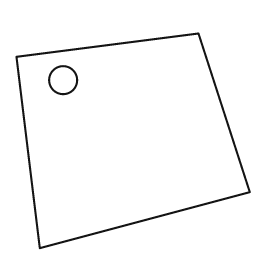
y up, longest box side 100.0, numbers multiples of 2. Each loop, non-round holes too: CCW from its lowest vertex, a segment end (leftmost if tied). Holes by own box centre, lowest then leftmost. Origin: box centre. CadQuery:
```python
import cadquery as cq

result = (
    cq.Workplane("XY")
    .moveTo(-40.0, -46.0)
    .lineTo(50.0, -22.0)
    .lineTo(28.0, 46.0)
    .lineTo(-50.0, 36.0)
    .close()
    .moveTo(-30.0, 26.0)
    .circle(6.0)
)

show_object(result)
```